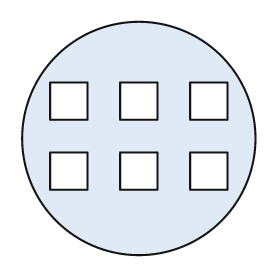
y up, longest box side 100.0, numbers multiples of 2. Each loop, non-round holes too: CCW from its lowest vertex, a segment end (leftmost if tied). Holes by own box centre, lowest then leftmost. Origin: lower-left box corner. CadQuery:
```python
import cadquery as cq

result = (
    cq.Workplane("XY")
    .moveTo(50.0, 50.0)
    .circle(50.0)
    .moveTo(12.0, 28.0)
    .lineTo(28.0, 28.0)
    .lineTo(28.0, 44.0)
    .lineTo(12.0, 44.0)
    .close()
    .moveTo(42.0, 28.0)
    .lineTo(58.0, 28.0)
    .lineTo(58.0, 44.0)
    .lineTo(42.0, 44.0)
    .close()
    .moveTo(72.0, 28.0)
    .lineTo(88.0, 28.0)
    .lineTo(88.0, 44.0)
    .lineTo(72.0, 44.0)
    .close()
    .moveTo(12.0, 58.0)
    .lineTo(28.0, 58.0)
    .lineTo(28.0, 74.0)
    .lineTo(12.0, 74.0)
    .close()
    .moveTo(42.0, 58.0)
    .lineTo(58.0, 58.0)
    .lineTo(58.0, 74.0)
    .lineTo(42.0, 74.0)
    .close()
    .moveTo(72.0, 58.0)
    .lineTo(88.0, 58.0)
    .lineTo(88.0, 74.0)
    .lineTo(72.0, 74.0)
    .close()
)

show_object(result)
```